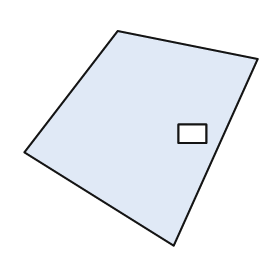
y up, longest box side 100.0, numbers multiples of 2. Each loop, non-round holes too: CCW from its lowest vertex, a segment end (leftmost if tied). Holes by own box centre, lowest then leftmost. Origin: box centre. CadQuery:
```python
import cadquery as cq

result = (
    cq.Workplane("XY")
    .moveTo(14.0, -46.0)
    .lineTo(50.0, 34.0)
    .lineTo(-10.0, 46.0)
    .lineTo(-50.0, -6.0)
    .close()
    .moveTo(16.0, -2.0)
    .lineTo(28.0, -2.0)
    .lineTo(28.0, 6.0)
    .lineTo(16.0, 6.0)
    .close()
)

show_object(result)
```